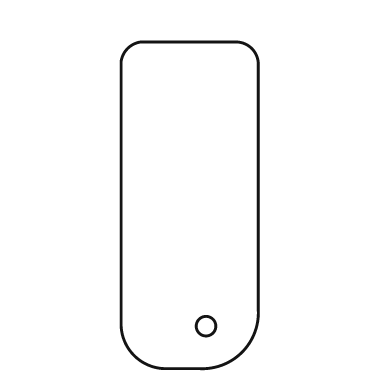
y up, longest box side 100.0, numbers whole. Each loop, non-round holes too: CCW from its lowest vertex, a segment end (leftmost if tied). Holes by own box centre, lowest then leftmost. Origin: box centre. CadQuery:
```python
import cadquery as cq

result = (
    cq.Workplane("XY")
    .moveTo(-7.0, -50.0)
    .lineTo(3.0, -50.0)
    .threePointArc((16.0, -45.0), (21.0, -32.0))
    .lineTo(21.0, 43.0)
    .threePointArc((19.0, 48.0), (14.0, 50.0))
    .lineTo(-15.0, 50.0)
    .threePointArc((-19.0, 48.0), (-21.0, 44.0))
    .lineTo(-21.0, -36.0)
    .threePointArc((-17.0, -46.0), (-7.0, -50.0))
    .close()
    .moveTo(5.0, -37.0)
    .circle(3.0)
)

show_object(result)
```